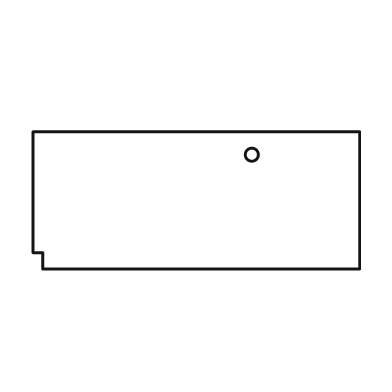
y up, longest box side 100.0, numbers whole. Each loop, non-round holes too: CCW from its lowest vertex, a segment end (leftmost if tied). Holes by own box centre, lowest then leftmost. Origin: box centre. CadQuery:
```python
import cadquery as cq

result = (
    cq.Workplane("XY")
    .moveTo(-47.0, -21.0)
    .lineTo(50.0, -21.0)
    .lineTo(50.0, 21.0)
    .lineTo(-50.0, 21.0)
    .lineTo(-50.0, -16.0)
    .lineTo(-47.0, -16.0)
    .close()
    .moveTo(17.0, 14.0)
    .circle(2.0)
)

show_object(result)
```